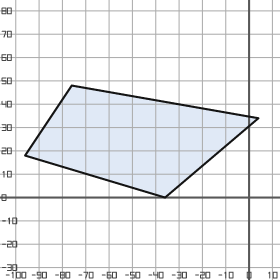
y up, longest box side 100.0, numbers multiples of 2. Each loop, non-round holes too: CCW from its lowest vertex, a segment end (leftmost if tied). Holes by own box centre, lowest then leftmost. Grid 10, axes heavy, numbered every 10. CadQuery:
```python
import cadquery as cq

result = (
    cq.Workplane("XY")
    .moveTo(-36.0, 0.0)
    .lineTo(4.0, 34.0)
    .lineTo(-76.0, 48.0)
    .lineTo(-96.0, 18.0)
    .close()
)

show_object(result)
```